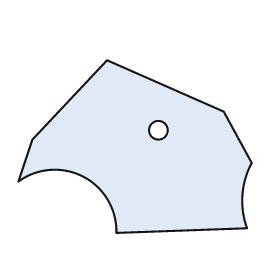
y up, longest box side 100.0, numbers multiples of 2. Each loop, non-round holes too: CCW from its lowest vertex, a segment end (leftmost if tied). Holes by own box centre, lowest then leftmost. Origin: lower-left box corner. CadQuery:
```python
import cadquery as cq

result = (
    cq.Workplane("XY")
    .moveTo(42.0, 0.0)
    .lineTo(98.0, 2.0)
    .threePointArc((96.0, 16.0), (100.0, 30.0))
    .lineTo(88.0, 52.0)
    .lineTo(38.0, 74.0)
    .lineTo(6.0, 40.0)
    .lineTo(0.0, 22.0)
    .threePointArc((28.0, 24.0), (42.0, 0.0))
    .close()
    .moveTo(60.0, 44.0)
    .circle(4.0)
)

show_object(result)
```